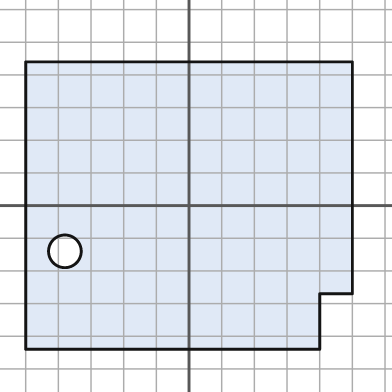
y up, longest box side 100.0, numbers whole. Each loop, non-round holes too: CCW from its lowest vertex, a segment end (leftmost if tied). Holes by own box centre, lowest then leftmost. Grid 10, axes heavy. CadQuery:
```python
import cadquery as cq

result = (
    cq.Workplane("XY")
    .moveTo(-50.0, -44.0)
    .lineTo(40.0, -44.0)
    .lineTo(40.0, -27.0)
    .lineTo(50.0, -27.0)
    .lineTo(50.0, 44.0)
    .lineTo(-50.0, 44.0)
    .close()
    .moveTo(-38.0, -14.0)
    .circle(5.0)
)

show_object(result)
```